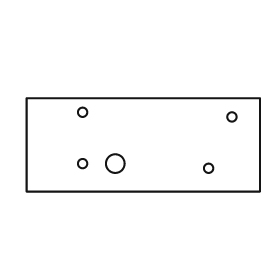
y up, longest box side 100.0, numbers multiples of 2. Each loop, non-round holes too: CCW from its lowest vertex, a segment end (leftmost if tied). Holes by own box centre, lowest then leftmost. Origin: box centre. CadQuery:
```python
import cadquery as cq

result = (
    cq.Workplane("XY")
    .moveTo(-50.0, -20.0)
    .lineTo(50.0, -20.0)
    .lineTo(50.0, 20.0)
    .lineTo(-50.0, 20.0)
    .close()
    .moveTo(28.0, -10.0)
    .circle(2.0)
    .moveTo(-26.0, -8.0)
    .circle(2.0)
    .moveTo(-12.0, -8.0)
    .circle(4.0)
    .moveTo(38.0, 12.0)
    .circle(2.0)
    .moveTo(-26.0, 14.0)
    .circle(2.0)
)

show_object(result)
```